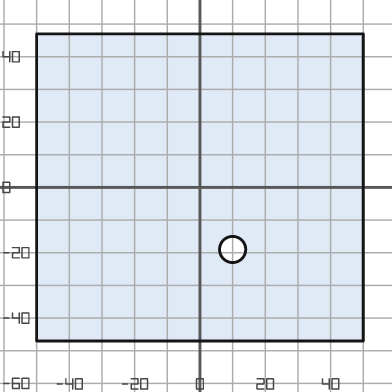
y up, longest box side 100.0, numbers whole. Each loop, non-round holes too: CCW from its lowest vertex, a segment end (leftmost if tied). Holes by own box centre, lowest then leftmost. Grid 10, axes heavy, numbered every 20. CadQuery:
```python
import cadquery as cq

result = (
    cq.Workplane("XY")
    .moveTo(-50.0, -47.0)
    .lineTo(50.0, -47.0)
    .lineTo(50.0, 47.0)
    .lineTo(-50.0, 47.0)
    .close()
    .moveTo(10.0, -19.0)
    .circle(4.0)
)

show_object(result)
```